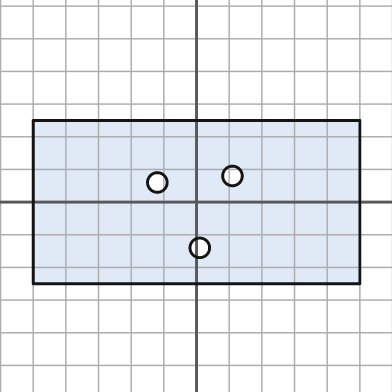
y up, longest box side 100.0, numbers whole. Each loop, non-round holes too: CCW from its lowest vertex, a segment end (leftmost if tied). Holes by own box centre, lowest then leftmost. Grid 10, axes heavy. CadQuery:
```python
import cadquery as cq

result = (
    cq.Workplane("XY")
    .moveTo(-50.0, -25.0)
    .lineTo(50.0, -25.0)
    .lineTo(50.0, 25.0)
    .lineTo(-50.0, 25.0)
    .close()
    .moveTo(1.0, -14.0)
    .circle(3.0)
    .moveTo(-12.0, 6.0)
    .circle(3.0)
    .moveTo(11.0, 8.0)
    .circle(3.0)
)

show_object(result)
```